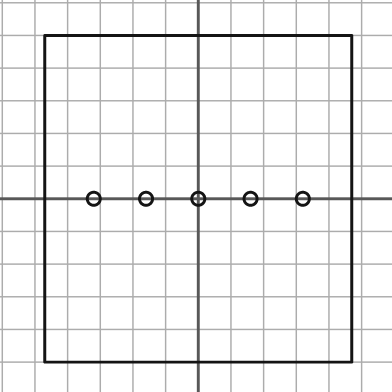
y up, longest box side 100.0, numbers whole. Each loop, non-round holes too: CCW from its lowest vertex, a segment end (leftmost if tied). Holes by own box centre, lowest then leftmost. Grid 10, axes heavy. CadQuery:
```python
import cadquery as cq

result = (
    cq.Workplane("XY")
    .moveTo(-47.0, -50.0)
    .lineTo(47.0, -50.0)
    .lineTo(47.0, 50.0)
    .lineTo(-47.0, 50.0)
    .close()
    .moveTo(-32.0, 0.0)
    .circle(2.0)
    .moveTo(-16.0, 0.0)
    .circle(2.0)
    .moveTo(0.0, 0.0)
    .circle(2.0)
    .moveTo(16.0, 0.0)
    .circle(2.0)
    .moveTo(32.0, 0.0)
    .circle(2.0)
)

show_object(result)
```